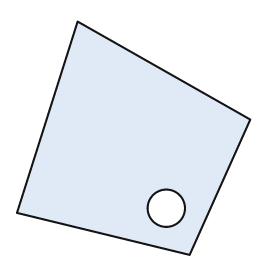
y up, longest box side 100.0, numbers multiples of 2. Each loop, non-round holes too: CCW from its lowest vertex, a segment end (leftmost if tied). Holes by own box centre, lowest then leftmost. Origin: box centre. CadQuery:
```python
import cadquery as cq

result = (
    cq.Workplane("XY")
    .moveTo(24.0, -50.0)
    .lineTo(50.0, 8.0)
    .lineTo(-24.0, 50.0)
    .lineTo(-50.0, -32.0)
    .close()
    .moveTo(14.0, -30.0)
    .circle(8.0)
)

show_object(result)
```